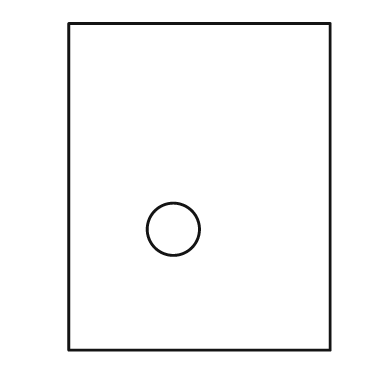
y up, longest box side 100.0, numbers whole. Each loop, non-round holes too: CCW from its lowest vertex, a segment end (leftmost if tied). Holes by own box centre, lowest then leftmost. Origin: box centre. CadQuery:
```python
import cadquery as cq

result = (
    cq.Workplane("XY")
    .moveTo(-40.0, -50.0)
    .lineTo(40.0, -50.0)
    .lineTo(40.0, 50.0)
    .lineTo(-40.0, 50.0)
    .close()
    .moveTo(-8.0, -13.0)
    .circle(8.0)
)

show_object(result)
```